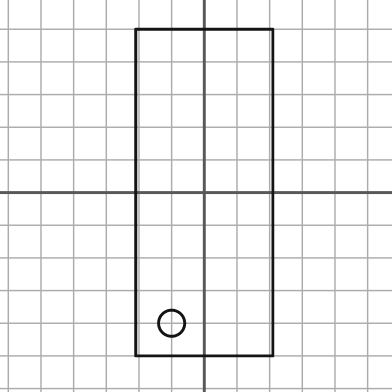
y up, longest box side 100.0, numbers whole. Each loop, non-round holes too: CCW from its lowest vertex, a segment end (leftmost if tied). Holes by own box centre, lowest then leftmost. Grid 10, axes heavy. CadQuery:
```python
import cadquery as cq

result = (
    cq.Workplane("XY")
    .moveTo(-21.0, -50.0)
    .lineTo(21.0, -50.0)
    .lineTo(21.0, 50.0)
    .lineTo(-21.0, 50.0)
    .close()
    .moveTo(-10.0, -40.0)
    .circle(4.0)
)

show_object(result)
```